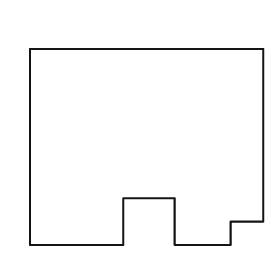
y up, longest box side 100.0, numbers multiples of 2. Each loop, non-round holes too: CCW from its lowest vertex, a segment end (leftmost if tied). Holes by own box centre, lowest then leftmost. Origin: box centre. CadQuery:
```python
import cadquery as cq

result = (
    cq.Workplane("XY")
    .moveTo(-50.0, -42.0)
    .lineTo(-10.0, -42.0)
    .lineTo(-10.0, -22.0)
    .lineTo(12.0, -22.0)
    .lineTo(12.0, -42.0)
    .lineTo(36.0, -42.0)
    .lineTo(36.0, -32.0)
    .lineTo(50.0, -32.0)
    .lineTo(50.0, 42.0)
    .lineTo(-50.0, 42.0)
    .close()
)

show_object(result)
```